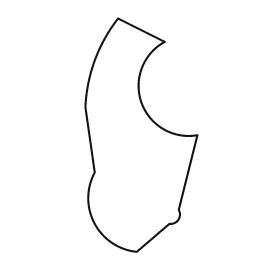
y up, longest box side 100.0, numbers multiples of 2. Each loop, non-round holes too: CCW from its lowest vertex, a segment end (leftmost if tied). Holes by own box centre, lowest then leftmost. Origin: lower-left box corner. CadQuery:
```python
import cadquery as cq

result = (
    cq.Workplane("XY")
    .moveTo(22.0, 0.0)
    .lineTo(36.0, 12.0)
    .threePointArc((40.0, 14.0), (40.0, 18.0))
    .lineTo(48.0, 50.0)
    .threePointArc((24.0, 64.0), (34.0, 90.0))
    .lineTo(14.0, 100.0)
    .threePointArc((4.0, 82.0), (0.0, 62.0))
    .lineTo(4.0, 34.0)
    .threePointArc((4.0, 12.0), (22.0, 0.0))
    .close()
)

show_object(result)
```